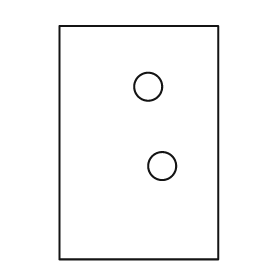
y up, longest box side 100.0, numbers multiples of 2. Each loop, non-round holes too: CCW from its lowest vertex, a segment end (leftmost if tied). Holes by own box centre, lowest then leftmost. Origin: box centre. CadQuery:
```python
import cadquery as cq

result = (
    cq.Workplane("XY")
    .moveTo(-34.0, -50.0)
    .lineTo(34.0, -50.0)
    .lineTo(34.0, 50.0)
    .lineTo(-34.0, 50.0)
    .close()
    .moveTo(10.0, -10.0)
    .circle(6.0)
    .moveTo(4.0, 24.0)
    .circle(6.0)
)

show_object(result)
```